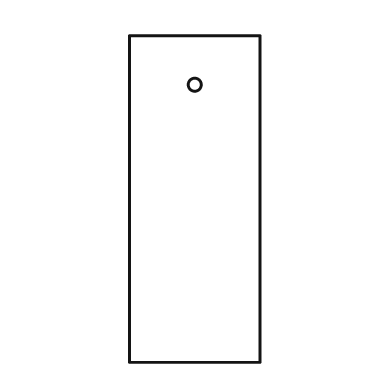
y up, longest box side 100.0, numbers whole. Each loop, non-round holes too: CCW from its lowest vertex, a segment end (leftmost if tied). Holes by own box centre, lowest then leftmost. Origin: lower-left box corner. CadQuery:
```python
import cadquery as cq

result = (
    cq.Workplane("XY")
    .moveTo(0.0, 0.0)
    .lineTo(40.0, 0.0)
    .lineTo(40.0, 100.0)
    .lineTo(0.0, 100.0)
    .close()
    .moveTo(20.0, 85.0)
    .circle(2.0)
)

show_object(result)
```